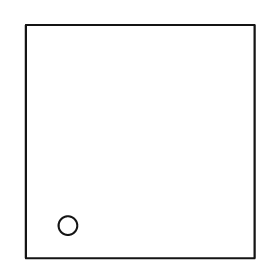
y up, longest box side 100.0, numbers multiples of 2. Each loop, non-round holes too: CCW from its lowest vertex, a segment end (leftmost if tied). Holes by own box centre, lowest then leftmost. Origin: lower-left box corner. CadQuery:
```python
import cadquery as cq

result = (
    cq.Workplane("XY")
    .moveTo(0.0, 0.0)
    .lineTo(98.0, 0.0)
    .lineTo(98.0, 100.0)
    .lineTo(0.0, 100.0)
    .close()
    .moveTo(18.0, 14.0)
    .circle(4.0)
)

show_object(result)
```